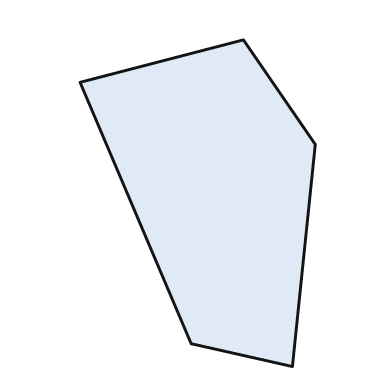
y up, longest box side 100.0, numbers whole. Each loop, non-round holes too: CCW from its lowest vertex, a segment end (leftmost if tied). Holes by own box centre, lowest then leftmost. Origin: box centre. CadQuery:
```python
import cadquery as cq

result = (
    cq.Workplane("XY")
    .moveTo(29.0, -50.0)
    .lineTo(36.0, 18.0)
    .lineTo(14.0, 50.0)
    .lineTo(-36.0, 37.0)
    .lineTo(-2.0, -43.0)
    .close()
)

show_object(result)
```